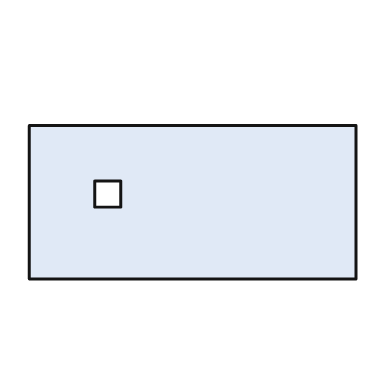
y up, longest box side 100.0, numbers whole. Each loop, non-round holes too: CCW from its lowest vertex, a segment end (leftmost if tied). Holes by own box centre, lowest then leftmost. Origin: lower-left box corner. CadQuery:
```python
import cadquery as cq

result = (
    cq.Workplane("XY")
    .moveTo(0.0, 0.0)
    .lineTo(100.0, 0.0)
    .lineTo(100.0, 47.0)
    .lineTo(0.0, 47.0)
    .close()
    .moveTo(20.0, 22.0)
    .lineTo(28.0, 22.0)
    .lineTo(28.0, 30.0)
    .lineTo(20.0, 30.0)
    .close()
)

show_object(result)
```